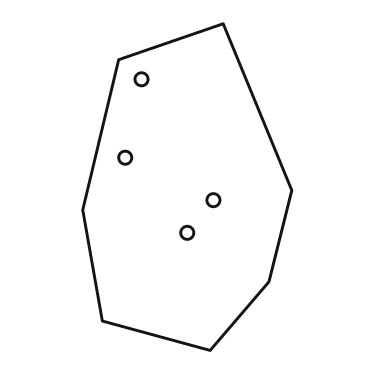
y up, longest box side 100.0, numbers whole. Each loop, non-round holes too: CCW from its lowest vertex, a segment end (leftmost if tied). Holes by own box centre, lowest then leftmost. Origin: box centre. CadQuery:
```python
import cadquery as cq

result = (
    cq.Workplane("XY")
    .moveTo(7.0, -50.0)
    .lineTo(25.0, -29.0)
    .lineTo(32.0, -1.0)
    .lineTo(11.0, 50.0)
    .lineTo(-21.0, 39.0)
    .lineTo(-32.0, -7.0)
    .lineTo(-26.0, -41.0)
    .close()
    .moveTo(0.0, -14.0)
    .circle(2.0)
    .moveTo(8.0, -4.0)
    .circle(2.0)
    .moveTo(-19.0, 9.0)
    .circle(2.0)
    .moveTo(-14.0, 33.0)
    .circle(2.0)
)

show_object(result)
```